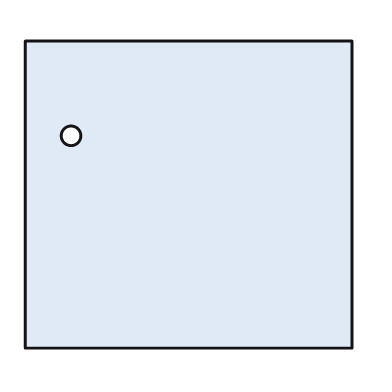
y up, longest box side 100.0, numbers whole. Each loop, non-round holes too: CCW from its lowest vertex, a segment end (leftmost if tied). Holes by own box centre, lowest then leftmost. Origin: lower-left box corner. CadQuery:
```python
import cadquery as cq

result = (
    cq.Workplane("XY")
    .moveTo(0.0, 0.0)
    .lineTo(100.0, 0.0)
    .lineTo(100.0, 94.0)
    .lineTo(0.0, 94.0)
    .close()
    .moveTo(14.0, 65.0)
    .circle(3.0)
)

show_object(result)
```